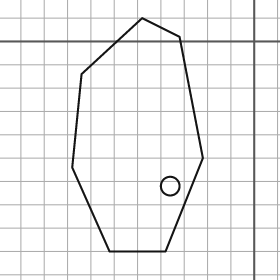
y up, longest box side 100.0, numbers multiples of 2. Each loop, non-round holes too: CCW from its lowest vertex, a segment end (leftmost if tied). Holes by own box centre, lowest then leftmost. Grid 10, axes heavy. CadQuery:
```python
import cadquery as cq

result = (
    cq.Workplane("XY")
    .moveTo(-62.0, -90.0)
    .lineTo(-38.0, -90.0)
    .lineTo(-22.0, -50.0)
    .lineTo(-32.0, 2.0)
    .lineTo(-48.0, 10.0)
    .lineTo(-74.0, -14.0)
    .lineTo(-78.0, -54.0)
    .close()
    .moveTo(-36.0, -62.0)
    .circle(4.0)
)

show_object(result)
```